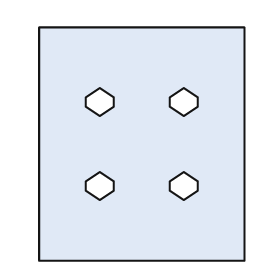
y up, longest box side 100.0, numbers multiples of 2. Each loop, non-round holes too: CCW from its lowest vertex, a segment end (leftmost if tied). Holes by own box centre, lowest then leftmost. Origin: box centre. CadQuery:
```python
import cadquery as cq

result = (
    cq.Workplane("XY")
    .moveTo(-44.0, -50.0)
    .lineTo(44.0, -50.0)
    .lineTo(44.0, 50.0)
    .lineTo(-44.0, 50.0)
    .close()
    .moveTo(-18.0, -24.0)
    .lineTo(-12.0, -20.0)
    .lineTo(-12.0, -16.0)
    .lineTo(-18.0, -12.0)
    .lineTo(-24.0, -16.0)
    .lineTo(-24.0, -20.0)
    .close()
    .moveTo(18.0, -24.0)
    .lineTo(24.0, -20.0)
    .lineTo(24.0, -16.0)
    .lineTo(18.0, -12.0)
    .lineTo(12.0, -16.0)
    .lineTo(12.0, -20.0)
    .close()
    .moveTo(-18.0, 12.0)
    .lineTo(-12.0, 16.0)
    .lineTo(-12.0, 20.0)
    .lineTo(-18.0, 24.0)
    .lineTo(-24.0, 20.0)
    .lineTo(-24.0, 16.0)
    .close()
    .moveTo(18.0, 12.0)
    .lineTo(24.0, 16.0)
    .lineTo(24.0, 20.0)
    .lineTo(18.0, 24.0)
    .lineTo(12.0, 20.0)
    .lineTo(12.0, 16.0)
    .close()
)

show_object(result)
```